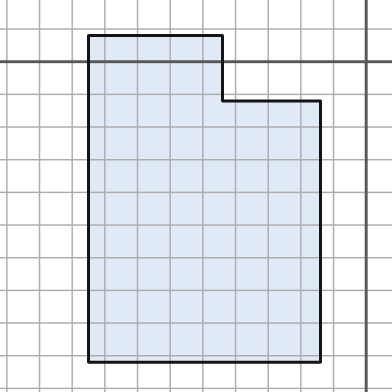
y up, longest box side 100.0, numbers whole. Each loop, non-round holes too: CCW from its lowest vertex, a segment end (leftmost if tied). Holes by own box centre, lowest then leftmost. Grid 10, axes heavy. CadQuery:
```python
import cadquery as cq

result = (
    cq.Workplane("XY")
    .moveTo(-85.0, -92.0)
    .lineTo(-14.0, -92.0)
    .lineTo(-14.0, -12.0)
    .lineTo(-44.0, -12.0)
    .lineTo(-44.0, 8.0)
    .lineTo(-85.0, 8.0)
    .close()
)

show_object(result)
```